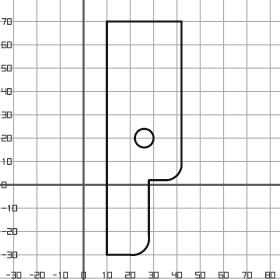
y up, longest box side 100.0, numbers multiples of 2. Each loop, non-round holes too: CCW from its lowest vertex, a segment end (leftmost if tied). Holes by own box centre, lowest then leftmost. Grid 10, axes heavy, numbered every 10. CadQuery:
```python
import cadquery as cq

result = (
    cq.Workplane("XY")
    .moveTo(10.0, -30.0)
    .lineTo(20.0, -30.0)
    .threePointArc((26.0, -28.0), (28.0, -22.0))
    .lineTo(28.0, 2.0)
    .lineTo(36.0, 2.0)
    .threePointArc((40.0, 4.0), (42.0, 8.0))
    .lineTo(42.0, 70.0)
    .lineTo(10.0, 70.0)
    .close()
    .moveTo(26.0, 20.0)
    .circle(4.0)
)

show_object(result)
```